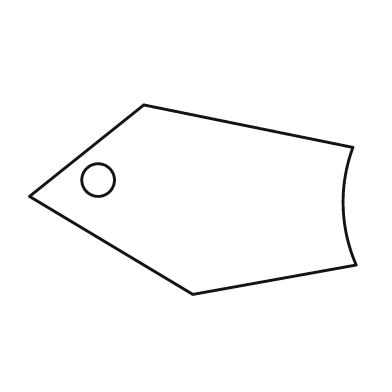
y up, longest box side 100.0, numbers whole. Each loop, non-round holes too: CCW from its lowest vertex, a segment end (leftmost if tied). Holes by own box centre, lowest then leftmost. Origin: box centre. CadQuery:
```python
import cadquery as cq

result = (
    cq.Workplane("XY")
    .moveTo(0.0, -29.0)
    .lineTo(50.0, -20.0)
    .threePointArc((46.0, -2.0), (49.0, 16.0))
    .lineTo(-15.0, 29.0)
    .lineTo(-50.0, 1.0)
    .close()
    .moveTo(-29.0, 6.0)
    .circle(5.0)
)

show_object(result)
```